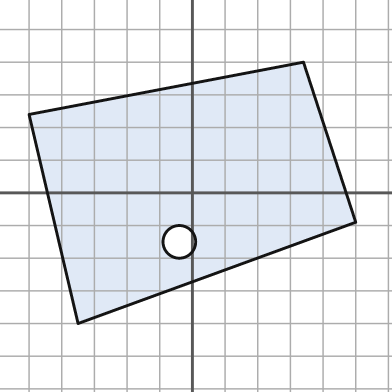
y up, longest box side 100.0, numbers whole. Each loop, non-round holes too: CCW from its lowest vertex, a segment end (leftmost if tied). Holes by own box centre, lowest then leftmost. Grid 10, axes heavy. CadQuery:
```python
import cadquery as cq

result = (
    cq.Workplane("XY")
    .moveTo(-35.0, -40.0)
    .lineTo(50.0, -9.0)
    .lineTo(34.0, 40.0)
    .lineTo(-50.0, 24.0)
    .close()
    .moveTo(-4.0, -15.0)
    .circle(5.0)
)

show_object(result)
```